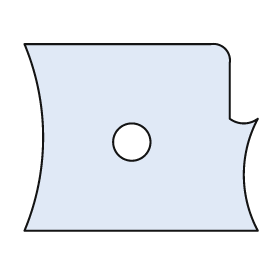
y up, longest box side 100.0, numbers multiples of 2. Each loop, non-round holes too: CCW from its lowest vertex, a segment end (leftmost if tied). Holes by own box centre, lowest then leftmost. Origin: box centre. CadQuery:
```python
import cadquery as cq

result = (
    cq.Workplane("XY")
    .moveTo(-50.0, -40.0)
    .lineTo(50.0, -40.0)
    .threePointArc((44.0, -16.0), (50.0, 8.0))
    .threePointArc((44.0, 6.0), (38.0, 8.0))
    .lineTo(38.0, 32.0)
    .threePointArc((36.0, 38.0), (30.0, 40.0))
    .lineTo(-50.0, 40.0)
    .threePointArc((-42.0, 0.0), (-50.0, -40.0))
    .close()
    .moveTo(-4.0, -2.0)
    .circle(8.0)
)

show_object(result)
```